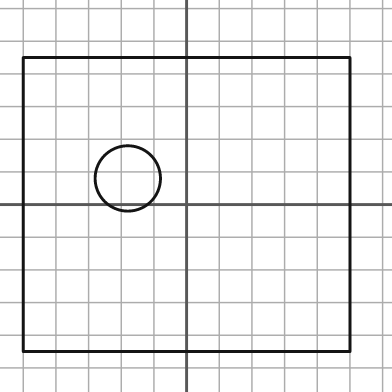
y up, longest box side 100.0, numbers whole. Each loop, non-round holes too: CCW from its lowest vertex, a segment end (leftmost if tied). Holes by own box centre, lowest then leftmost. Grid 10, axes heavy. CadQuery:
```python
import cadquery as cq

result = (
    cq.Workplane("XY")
    .moveTo(-50.0, -45.0)
    .lineTo(50.0, -45.0)
    .lineTo(50.0, 45.0)
    .lineTo(-50.0, 45.0)
    .close()
    .moveTo(-18.0, 8.0)
    .circle(10.0)
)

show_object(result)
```